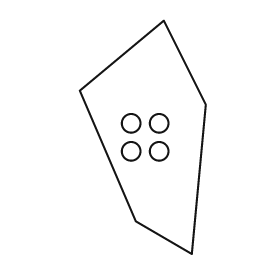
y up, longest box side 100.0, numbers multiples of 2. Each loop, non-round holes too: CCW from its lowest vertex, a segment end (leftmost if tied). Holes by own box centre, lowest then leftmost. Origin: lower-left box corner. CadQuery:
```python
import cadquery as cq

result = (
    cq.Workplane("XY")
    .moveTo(48.0, 0.0)
    .lineTo(54.0, 64.0)
    .lineTo(36.0, 100.0)
    .lineTo(0.0, 70.0)
    .lineTo(24.0, 14.0)
    .close()
    .moveTo(22.0, 44.0)
    .circle(4.0)
    .moveTo(34.0, 44.0)
    .circle(4.0)
    .moveTo(22.0, 56.0)
    .circle(4.0)
    .moveTo(34.0, 56.0)
    .circle(4.0)
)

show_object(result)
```